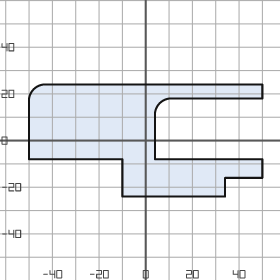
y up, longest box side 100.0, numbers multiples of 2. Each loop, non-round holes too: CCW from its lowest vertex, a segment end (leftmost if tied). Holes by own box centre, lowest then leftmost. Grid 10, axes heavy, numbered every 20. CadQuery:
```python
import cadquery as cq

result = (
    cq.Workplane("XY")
    .moveTo(-10.0, -24.0)
    .lineTo(34.0, -24.0)
    .lineTo(34.0, -16.0)
    .lineTo(50.0, -16.0)
    .lineTo(50.0, -8.0)
    .lineTo(4.0, -8.0)
    .lineTo(4.0, 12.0)
    .threePointArc((6.0, 16.0), (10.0, 18.0))
    .lineTo(50.0, 18.0)
    .lineTo(50.0, 24.0)
    .lineTo(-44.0, 24.0)
    .threePointArc((-48.0, 22.0), (-50.0, 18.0))
    .lineTo(-50.0, -8.0)
    .lineTo(-10.0, -8.0)
    .close()
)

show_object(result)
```